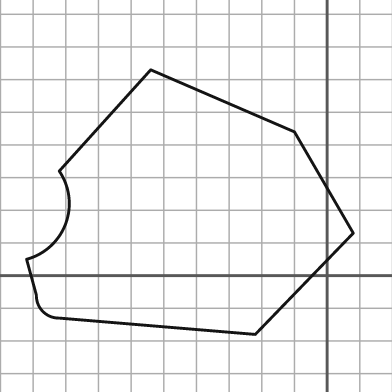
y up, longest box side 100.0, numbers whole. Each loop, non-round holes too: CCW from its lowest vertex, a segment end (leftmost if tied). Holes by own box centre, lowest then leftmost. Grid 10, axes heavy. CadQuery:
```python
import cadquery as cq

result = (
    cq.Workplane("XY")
    .moveTo(-22.0, -18.0)
    .lineTo(8.0, 13.0)
    .lineTo(-10.0, 44.0)
    .lineTo(-54.0, 63.0)
    .lineTo(-82.0, 32.0)
    .threePointArc((-80.0, 16.0), (-92.0, 5.0))
    .lineTo(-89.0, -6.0)
    .threePointArc((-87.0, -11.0), (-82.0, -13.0))
    .close()
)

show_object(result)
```